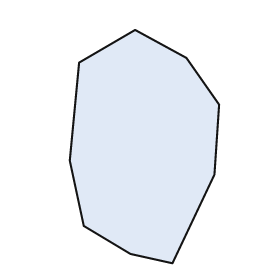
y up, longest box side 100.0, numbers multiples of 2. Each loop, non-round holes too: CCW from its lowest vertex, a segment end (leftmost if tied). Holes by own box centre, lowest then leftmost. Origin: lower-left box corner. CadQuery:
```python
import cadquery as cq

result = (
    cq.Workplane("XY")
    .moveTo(44.0, 0.0)
    .lineTo(62.0, 38.0)
    .lineTo(64.0, 68.0)
    .lineTo(50.0, 88.0)
    .lineTo(28.0, 100.0)
    .lineTo(4.0, 86.0)
    .lineTo(0.0, 44.0)
    .lineTo(6.0, 16.0)
    .lineTo(26.0, 4.0)
    .close()
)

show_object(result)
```